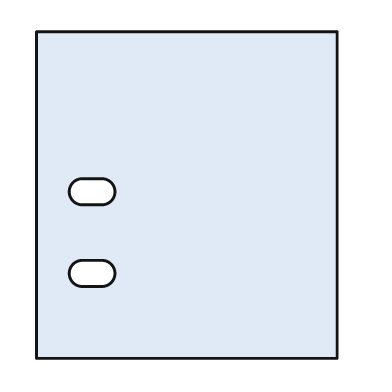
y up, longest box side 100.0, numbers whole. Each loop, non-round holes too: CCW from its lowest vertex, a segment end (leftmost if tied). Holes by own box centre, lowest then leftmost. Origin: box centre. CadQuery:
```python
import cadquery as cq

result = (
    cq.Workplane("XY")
    .moveTo(-46.0, -50.0)
    .lineTo(46.0, -50.0)
    .lineTo(46.0, 50.0)
    .lineTo(-46.0, 50.0)
    .close()
    .moveTo(-32.0, -28.0)
    .lineTo(-26.0, -28.0)
    .threePointArc((-22.0, -24.0), (-26.0, -20.0))
    .lineTo(-32.0, -20.0)
    .threePointArc((-36.0, -24.0), (-32.0, -28.0))
    .close()
    .moveTo(-32.0, -3.0)
    .lineTo(-26.0, -3.0)
    .threePointArc((-22.0, 1.0), (-26.0, 5.0))
    .lineTo(-32.0, 5.0)
    .threePointArc((-36.0, 1.0), (-32.0, -3.0))
    .close()
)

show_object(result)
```